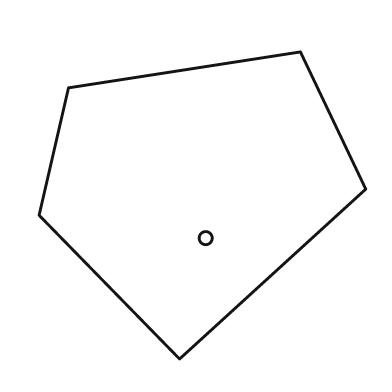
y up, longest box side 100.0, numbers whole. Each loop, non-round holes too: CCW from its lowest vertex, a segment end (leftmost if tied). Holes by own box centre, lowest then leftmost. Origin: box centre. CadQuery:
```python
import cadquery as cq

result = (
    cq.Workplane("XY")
    .moveTo(-7.0, -47.0)
    .lineTo(50.0, 5.0)
    .lineTo(30.0, 47.0)
    .lineTo(-41.0, 36.0)
    .lineTo(-50.0, -3.0)
    .close()
    .moveTo(1.0, -10.0)
    .circle(2.0)
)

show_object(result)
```